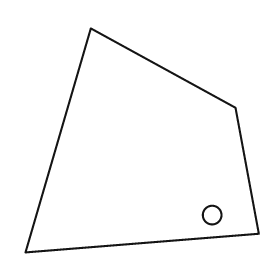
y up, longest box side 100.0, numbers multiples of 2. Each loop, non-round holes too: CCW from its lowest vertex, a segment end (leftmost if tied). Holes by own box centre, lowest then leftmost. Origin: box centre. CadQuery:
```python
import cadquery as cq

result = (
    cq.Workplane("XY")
    .moveTo(-50.0, -48.0)
    .lineTo(50.0, -40.0)
    .lineTo(40.0, 14.0)
    .lineTo(-22.0, 48.0)
    .close()
    .moveTo(30.0, -32.0)
    .circle(4.0)
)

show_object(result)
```